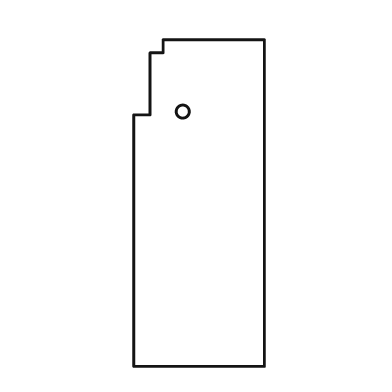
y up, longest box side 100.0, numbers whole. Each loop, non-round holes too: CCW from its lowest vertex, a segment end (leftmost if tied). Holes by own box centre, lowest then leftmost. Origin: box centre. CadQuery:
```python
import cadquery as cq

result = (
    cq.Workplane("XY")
    .moveTo(-20.0, -50.0)
    .lineTo(20.0, -50.0)
    .lineTo(20.0, 50.0)
    .lineTo(-11.0, 50.0)
    .lineTo(-11.0, 46.0)
    .lineTo(-15.0, 46.0)
    .lineTo(-15.0, 27.0)
    .lineTo(-20.0, 27.0)
    .close()
    .moveTo(-5.0, 28.0)
    .circle(2.0)
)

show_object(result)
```